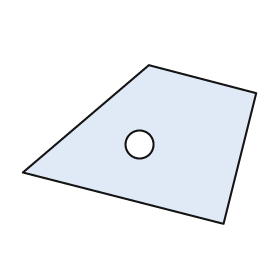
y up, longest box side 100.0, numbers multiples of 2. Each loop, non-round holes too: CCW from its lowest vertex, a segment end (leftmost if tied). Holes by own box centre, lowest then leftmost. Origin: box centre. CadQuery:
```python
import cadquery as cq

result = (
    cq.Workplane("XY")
    .moveTo(36.0, -34.0)
    .lineTo(50.0, 22.0)
    .lineTo(4.0, 34.0)
    .lineTo(-50.0, -12.0)
    .close()
    .moveTo(0.0, 0.0)
    .circle(6.0)
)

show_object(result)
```